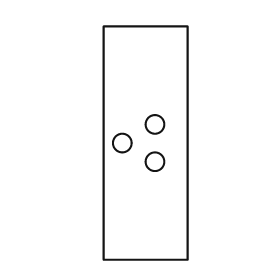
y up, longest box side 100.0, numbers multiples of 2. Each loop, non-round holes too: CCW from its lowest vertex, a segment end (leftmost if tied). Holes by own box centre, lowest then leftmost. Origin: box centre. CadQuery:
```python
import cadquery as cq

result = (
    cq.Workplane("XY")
    .moveTo(-18.0, -50.0)
    .lineTo(18.0, -50.0)
    .lineTo(18.0, 50.0)
    .lineTo(-18.0, 50.0)
    .close()
    .moveTo(4.0, -8.0)
    .circle(4.0)
    .moveTo(-10.0, 0.0)
    .circle(4.0)
    .moveTo(4.0, 8.0)
    .circle(4.0)
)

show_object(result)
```